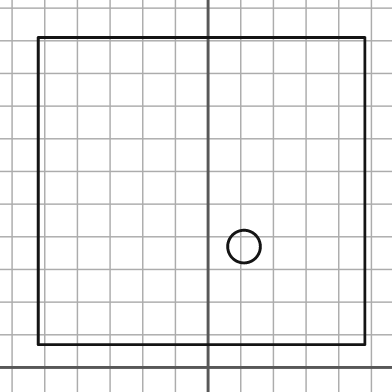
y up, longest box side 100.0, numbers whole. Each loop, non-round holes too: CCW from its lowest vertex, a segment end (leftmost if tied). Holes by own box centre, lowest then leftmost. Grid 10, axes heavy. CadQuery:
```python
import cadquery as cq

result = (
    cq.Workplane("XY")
    .moveTo(-52.0, 7.0)
    .lineTo(48.0, 7.0)
    .lineTo(48.0, 101.0)
    .lineTo(-52.0, 101.0)
    .close()
    .moveTo(11.0, 37.0)
    .circle(5.0)
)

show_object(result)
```